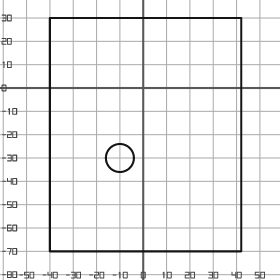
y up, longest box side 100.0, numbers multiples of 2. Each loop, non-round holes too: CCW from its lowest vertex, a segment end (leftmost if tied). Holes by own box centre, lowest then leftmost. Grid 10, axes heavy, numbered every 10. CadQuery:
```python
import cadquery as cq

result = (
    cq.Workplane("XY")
    .moveTo(-40.0, -70.0)
    .lineTo(42.0, -70.0)
    .lineTo(42.0, 30.0)
    .lineTo(-40.0, 30.0)
    .close()
    .moveTo(-10.0, -30.0)
    .circle(6.0)
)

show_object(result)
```